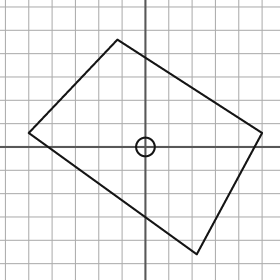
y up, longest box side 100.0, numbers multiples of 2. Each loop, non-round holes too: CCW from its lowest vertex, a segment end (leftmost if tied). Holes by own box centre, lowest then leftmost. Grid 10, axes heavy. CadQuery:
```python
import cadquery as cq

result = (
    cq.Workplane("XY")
    .moveTo(22.0, -46.0)
    .lineTo(50.0, 6.0)
    .lineTo(-12.0, 46.0)
    .lineTo(-50.0, 6.0)
    .close()
    .moveTo(0.0, 0.0)
    .circle(4.0)
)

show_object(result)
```